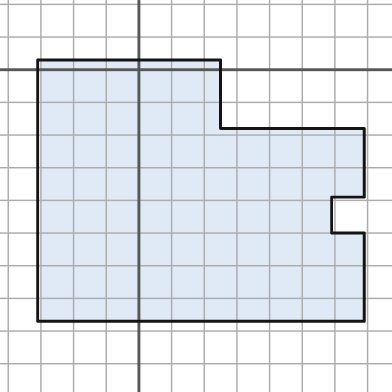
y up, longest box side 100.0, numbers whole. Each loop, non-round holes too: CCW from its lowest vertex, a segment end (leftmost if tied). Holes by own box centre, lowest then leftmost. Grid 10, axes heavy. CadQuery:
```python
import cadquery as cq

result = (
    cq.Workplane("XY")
    .moveTo(-31.0, -77.0)
    .lineTo(69.0, -77.0)
    .lineTo(69.0, -50.0)
    .lineTo(59.0, -50.0)
    .lineTo(59.0, -39.0)
    .lineTo(69.0, -39.0)
    .lineTo(69.0, -18.0)
    .lineTo(25.0, -18.0)
    .lineTo(25.0, 3.0)
    .lineTo(-31.0, 3.0)
    .close()
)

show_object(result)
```